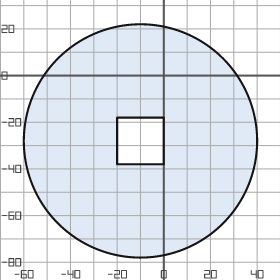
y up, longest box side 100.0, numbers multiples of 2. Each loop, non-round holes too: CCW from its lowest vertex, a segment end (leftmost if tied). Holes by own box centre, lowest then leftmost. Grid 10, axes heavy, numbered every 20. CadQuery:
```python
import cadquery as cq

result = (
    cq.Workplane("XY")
    .moveTo(-10.0, -28.0)
    .circle(50.0)
    .moveTo(-20.0, -38.0)
    .lineTo(0.0, -38.0)
    .lineTo(0.0, -18.0)
    .lineTo(-20.0, -18.0)
    .close()
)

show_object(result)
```